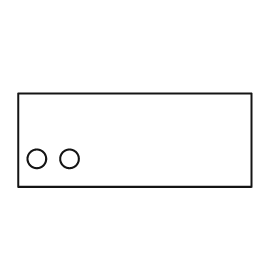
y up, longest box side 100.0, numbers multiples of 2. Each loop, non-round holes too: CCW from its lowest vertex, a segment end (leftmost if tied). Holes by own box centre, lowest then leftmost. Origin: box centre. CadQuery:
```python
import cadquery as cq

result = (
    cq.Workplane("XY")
    .moveTo(-50.0, -20.0)
    .lineTo(50.0, -20.0)
    .lineTo(50.0, 20.0)
    .lineTo(-50.0, 20.0)
    .close()
    .moveTo(-42.0, -8.0)
    .circle(4.0)
    .moveTo(-28.0, -8.0)
    .circle(4.0)
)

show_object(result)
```